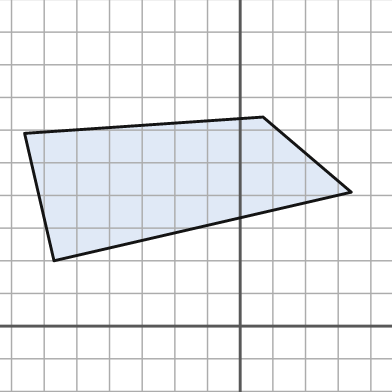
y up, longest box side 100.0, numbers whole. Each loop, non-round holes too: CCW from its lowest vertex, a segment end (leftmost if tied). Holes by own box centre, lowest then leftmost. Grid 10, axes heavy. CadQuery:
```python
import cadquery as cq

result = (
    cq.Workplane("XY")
    .moveTo(-57.0, 20.0)
    .lineTo(34.0, 41.0)
    .lineTo(7.0, 64.0)
    .lineTo(-66.0, 59.0)
    .close()
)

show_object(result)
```